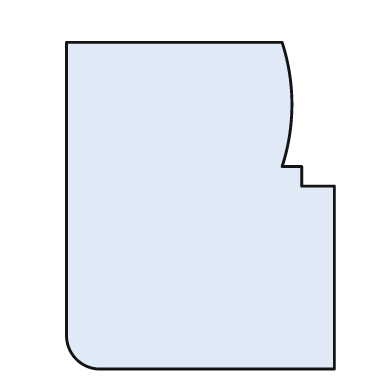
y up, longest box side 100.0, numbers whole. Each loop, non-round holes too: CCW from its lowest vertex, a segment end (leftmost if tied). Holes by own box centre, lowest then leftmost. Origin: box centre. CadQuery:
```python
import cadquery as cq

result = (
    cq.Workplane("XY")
    .moveTo(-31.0, -50.0)
    .lineTo(41.0, -50.0)
    .lineTo(41.0, 6.0)
    .lineTo(31.0, 6.0)
    .lineTo(31.0, 12.0)
    .lineTo(25.0, 12.0)
    .threePointArc((28.0, 31.0), (25.0, 50.0))
    .lineTo(-41.0, 50.0)
    .lineTo(-41.0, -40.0)
    .threePointArc((-38.0, -47.0), (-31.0, -50.0))
    .close()
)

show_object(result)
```